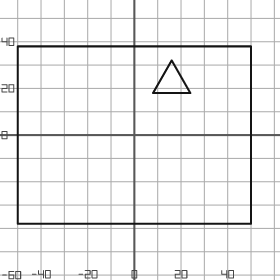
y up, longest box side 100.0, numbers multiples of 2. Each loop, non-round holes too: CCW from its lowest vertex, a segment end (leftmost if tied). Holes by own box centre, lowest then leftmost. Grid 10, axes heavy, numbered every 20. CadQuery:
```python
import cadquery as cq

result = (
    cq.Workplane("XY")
    .moveTo(-50.0, -38.0)
    .lineTo(50.0, -38.0)
    .lineTo(50.0, 38.0)
    .lineTo(-50.0, 38.0)
    .close()
    .moveTo(8.0, 18.0)
    .lineTo(24.0, 18.0)
    .lineTo(16.0, 32.0)
    .close()
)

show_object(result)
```